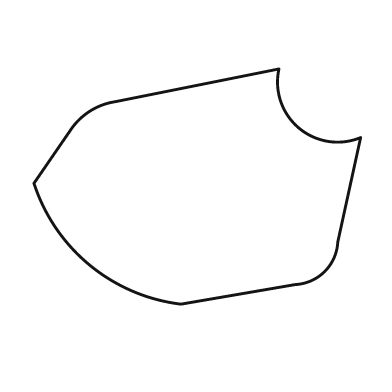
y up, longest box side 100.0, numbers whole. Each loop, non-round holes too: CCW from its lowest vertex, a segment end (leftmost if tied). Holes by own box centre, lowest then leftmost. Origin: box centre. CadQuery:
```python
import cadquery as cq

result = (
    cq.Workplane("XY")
    .moveTo(-5.0, -36.0)
    .lineTo(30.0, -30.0)
    .threePointArc((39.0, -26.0), (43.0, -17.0))
    .lineTo(50.0, 15.0)
    .threePointArc((31.0, 18.0), (25.0, 36.0))
    .lineTo(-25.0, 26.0)
    .threePointArc((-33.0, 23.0), (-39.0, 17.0))
    .lineTo(-50.0, 1.0)
    .threePointArc((-33.0, -24.0), (-5.0, -36.0))
    .close()
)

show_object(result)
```